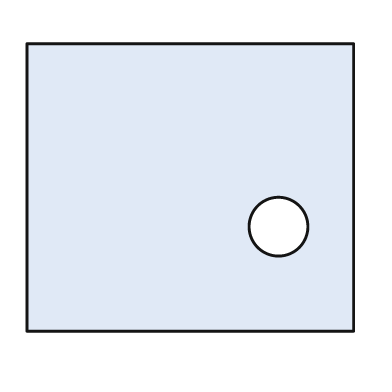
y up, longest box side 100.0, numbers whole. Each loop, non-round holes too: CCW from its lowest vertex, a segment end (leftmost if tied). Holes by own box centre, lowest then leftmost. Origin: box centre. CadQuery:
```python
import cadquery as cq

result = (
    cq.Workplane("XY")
    .moveTo(-50.0, -44.0)
    .lineTo(50.0, -44.0)
    .lineTo(50.0, 44.0)
    .lineTo(-50.0, 44.0)
    .close()
    .moveTo(27.0, -12.0)
    .circle(9.0)
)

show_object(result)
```